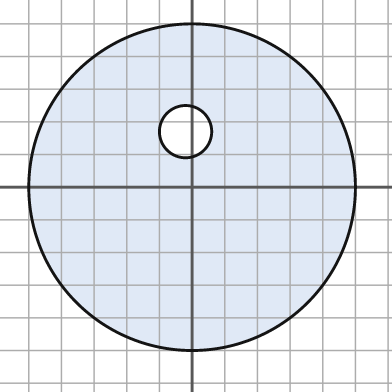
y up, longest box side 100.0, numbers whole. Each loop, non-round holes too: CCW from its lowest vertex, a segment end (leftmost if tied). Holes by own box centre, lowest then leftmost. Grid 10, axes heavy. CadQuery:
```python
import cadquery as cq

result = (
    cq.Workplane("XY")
    .moveTo(0.0, 0.0)
    .circle(50.0)
    .moveTo(-2.0, 17.0)
    .circle(8.0)
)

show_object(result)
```